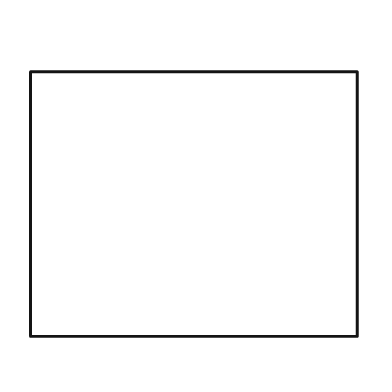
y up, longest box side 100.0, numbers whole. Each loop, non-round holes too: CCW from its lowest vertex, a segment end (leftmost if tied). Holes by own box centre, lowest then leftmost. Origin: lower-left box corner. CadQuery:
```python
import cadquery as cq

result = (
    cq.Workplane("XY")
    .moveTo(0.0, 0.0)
    .lineTo(100.0, 0.0)
    .lineTo(100.0, 81.0)
    .lineTo(0.0, 81.0)
    .close()
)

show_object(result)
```